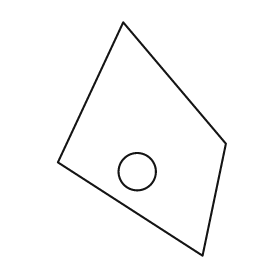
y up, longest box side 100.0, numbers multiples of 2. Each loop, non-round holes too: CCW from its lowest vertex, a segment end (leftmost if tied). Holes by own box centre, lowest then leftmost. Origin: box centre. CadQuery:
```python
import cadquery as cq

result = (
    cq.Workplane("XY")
    .moveTo(26.0, -50.0)
    .lineTo(36.0, -2.0)
    .lineTo(-8.0, 50.0)
    .lineTo(-36.0, -10.0)
    .close()
    .moveTo(-2.0, -14.0)
    .circle(8.0)
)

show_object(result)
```